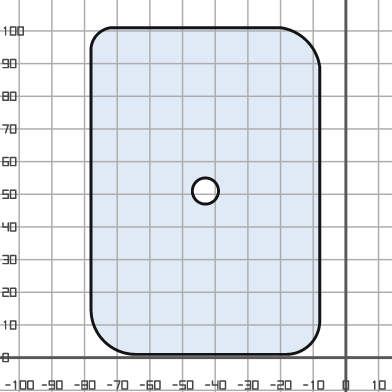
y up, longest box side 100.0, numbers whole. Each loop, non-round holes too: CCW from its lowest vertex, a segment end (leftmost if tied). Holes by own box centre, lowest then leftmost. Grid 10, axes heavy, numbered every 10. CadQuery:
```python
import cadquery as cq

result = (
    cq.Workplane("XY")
    .moveTo(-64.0, 1.0)
    .lineTo(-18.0, 1.0)
    .threePointArc((-11.0, 4.0), (-8.0, 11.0))
    .lineTo(-8.0, 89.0)
    .threePointArc((-12.0, 97.0), (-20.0, 101.0))
    .lineTo(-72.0, 101.0)
    .threePointArc((-76.0, 99.0), (-78.0, 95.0))
    .lineTo(-78.0, 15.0)
    .threePointArc((-74.0, 5.0), (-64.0, 1.0))
    .close()
    .moveTo(-43.0, 51.0)
    .circle(4.0)
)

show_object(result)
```